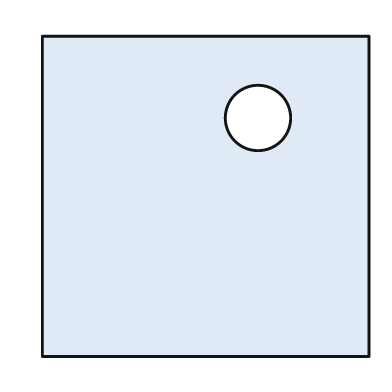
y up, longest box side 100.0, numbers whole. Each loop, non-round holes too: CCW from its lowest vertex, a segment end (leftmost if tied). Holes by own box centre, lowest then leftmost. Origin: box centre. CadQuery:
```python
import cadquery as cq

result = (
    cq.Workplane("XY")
    .moveTo(-50.0, -49.0)
    .lineTo(50.0, -49.0)
    .lineTo(50.0, 49.0)
    .lineTo(-50.0, 49.0)
    .close()
    .moveTo(16.0, 24.0)
    .circle(10.0)
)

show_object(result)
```